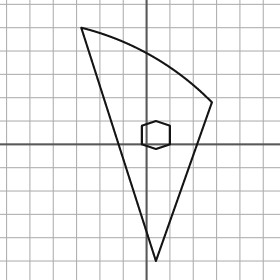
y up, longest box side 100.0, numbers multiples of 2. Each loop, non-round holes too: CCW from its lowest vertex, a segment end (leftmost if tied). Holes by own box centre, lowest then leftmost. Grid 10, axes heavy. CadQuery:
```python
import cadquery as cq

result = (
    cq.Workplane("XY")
    .moveTo(4.0, -50.0)
    .lineTo(28.0, 18.0)
    .threePointArc((2.0, 38.0), (-28.0, 50.0))
    .close()
    .moveTo(4.0, -2.0)
    .lineTo(10.0, 0.0)
    .lineTo(10.0, 8.0)
    .lineTo(4.0, 10.0)
    .lineTo(-2.0, 8.0)
    .lineTo(-2.0, 0.0)
    .close()
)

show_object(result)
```